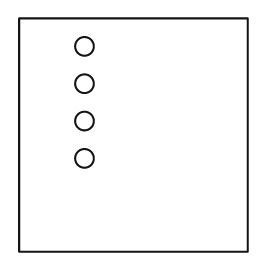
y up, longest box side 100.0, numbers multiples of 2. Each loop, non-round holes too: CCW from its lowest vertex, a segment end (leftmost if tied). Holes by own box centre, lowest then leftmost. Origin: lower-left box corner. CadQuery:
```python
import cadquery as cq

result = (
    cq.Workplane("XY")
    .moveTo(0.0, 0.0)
    .lineTo(98.0, 0.0)
    .lineTo(98.0, 100.0)
    .lineTo(0.0, 100.0)
    .close()
    .moveTo(28.0, 40.0)
    .circle(4.0)
    .moveTo(28.0, 56.0)
    .circle(4.0)
    .moveTo(28.0, 72.0)
    .circle(4.0)
    .moveTo(28.0, 88.0)
    .circle(4.0)
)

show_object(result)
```